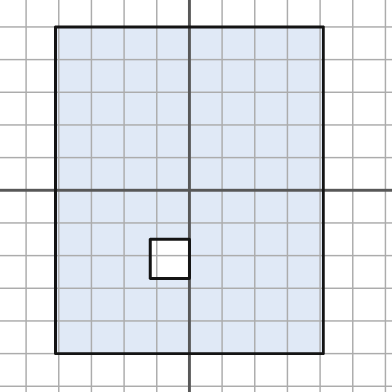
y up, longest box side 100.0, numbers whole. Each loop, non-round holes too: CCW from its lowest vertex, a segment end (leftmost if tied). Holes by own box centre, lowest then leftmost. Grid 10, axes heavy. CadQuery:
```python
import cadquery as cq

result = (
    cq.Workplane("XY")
    .moveTo(-41.0, -50.0)
    .lineTo(41.0, -50.0)
    .lineTo(41.0, 50.0)
    .lineTo(-41.0, 50.0)
    .close()
    .moveTo(-12.0, -27.0)
    .lineTo(0.0, -27.0)
    .lineTo(0.0, -15.0)
    .lineTo(-12.0, -15.0)
    .close()
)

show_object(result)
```